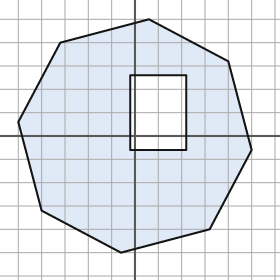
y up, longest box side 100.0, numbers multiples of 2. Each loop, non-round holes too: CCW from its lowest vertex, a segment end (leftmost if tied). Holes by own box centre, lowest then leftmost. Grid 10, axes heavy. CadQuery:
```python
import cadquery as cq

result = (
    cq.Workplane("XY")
    .moveTo(-6.0, -50.0)
    .lineTo(32.0, -40.0)
    .lineTo(50.0, -6.0)
    .lineTo(40.0, 32.0)
    .lineTo(6.0, 50.0)
    .lineTo(-32.0, 40.0)
    .lineTo(-50.0, 6.0)
    .lineTo(-40.0, -32.0)
    .close()
    .moveTo(-2.0, -6.0)
    .lineTo(22.0, -6.0)
    .lineTo(22.0, 26.0)
    .lineTo(-2.0, 26.0)
    .close()
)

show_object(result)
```